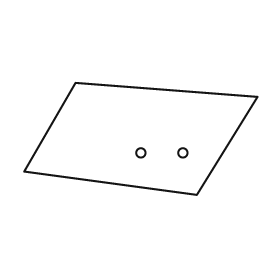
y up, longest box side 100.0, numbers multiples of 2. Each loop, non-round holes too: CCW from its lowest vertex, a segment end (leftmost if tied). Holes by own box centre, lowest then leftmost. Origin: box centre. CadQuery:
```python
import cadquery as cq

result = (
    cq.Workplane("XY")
    .moveTo(24.0, -24.0)
    .lineTo(50.0, 18.0)
    .lineTo(-28.0, 24.0)
    .lineTo(-50.0, -14.0)
    .close()
    .moveTo(0.0, -6.0)
    .circle(2.0)
    .moveTo(18.0, -6.0)
    .circle(2.0)
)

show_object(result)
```